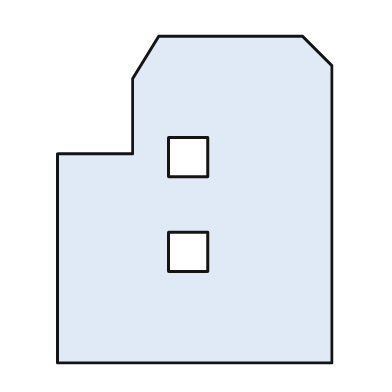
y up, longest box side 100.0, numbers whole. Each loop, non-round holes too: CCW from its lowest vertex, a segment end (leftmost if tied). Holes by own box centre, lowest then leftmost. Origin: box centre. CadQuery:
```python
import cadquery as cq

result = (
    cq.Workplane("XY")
    .moveTo(-42.0, -50.0)
    .lineTo(42.0, -50.0)
    .lineTo(42.0, 41.0)
    .lineTo(33.0, 50.0)
    .lineTo(-11.0, 50.0)
    .lineTo(-19.0, 37.0)
    .lineTo(-19.0, 14.0)
    .lineTo(-42.0, 14.0)
    .close()
    .moveTo(-8.0, -22.0)
    .lineTo(4.0, -22.0)
    .lineTo(4.0, -10.0)
    .lineTo(-8.0, -10.0)
    .close()
    .moveTo(-8.0, 7.0)
    .lineTo(4.0, 7.0)
    .lineTo(4.0, 19.0)
    .lineTo(-8.0, 19.0)
    .close()
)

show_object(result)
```